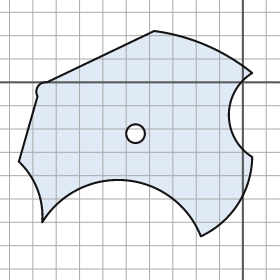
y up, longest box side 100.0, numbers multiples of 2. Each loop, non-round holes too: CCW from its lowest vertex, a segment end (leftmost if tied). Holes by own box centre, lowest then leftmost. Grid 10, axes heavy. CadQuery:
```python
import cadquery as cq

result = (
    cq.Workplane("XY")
    .moveTo(-18.0, -66.0)
    .threePointArc((-2.0, -52.0), (4.0, -32.0))
    .threePointArc((-6.0, -14.0), (4.0, 4.0))
    .threePointArc((-16.0, 16.0), (-38.0, 22.0))
    .lineTo(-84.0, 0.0)
    .threePointArc((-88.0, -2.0), (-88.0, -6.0))
    .lineTo(-96.0, -34.0)
    .threePointArc((-88.0, -46.0), (-86.0, -60.0))
    .threePointArc((-50.0, -42.0), (-18.0, -66.0))
    .close()
    .moveTo(-46.0, -22.0)
    .circle(4.0)
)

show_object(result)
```